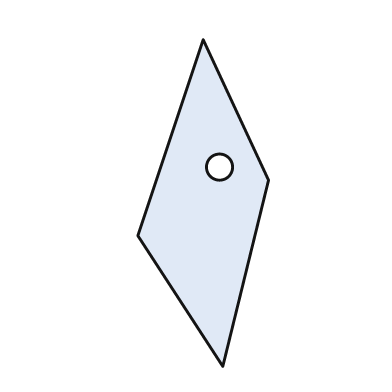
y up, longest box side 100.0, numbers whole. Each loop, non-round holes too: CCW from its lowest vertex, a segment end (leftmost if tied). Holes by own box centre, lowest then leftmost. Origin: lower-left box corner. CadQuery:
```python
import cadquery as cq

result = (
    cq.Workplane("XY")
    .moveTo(26.0, 0.0)
    .lineTo(40.0, 57.0)
    .lineTo(20.0, 100.0)
    .lineTo(0.0, 40.0)
    .close()
    .moveTo(25.0, 61.0)
    .circle(4.0)
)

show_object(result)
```